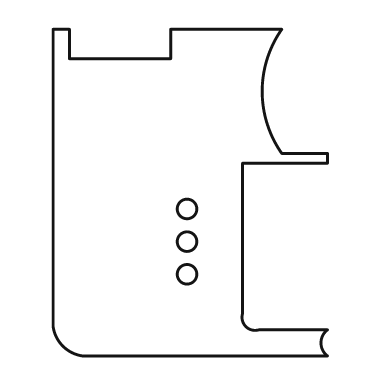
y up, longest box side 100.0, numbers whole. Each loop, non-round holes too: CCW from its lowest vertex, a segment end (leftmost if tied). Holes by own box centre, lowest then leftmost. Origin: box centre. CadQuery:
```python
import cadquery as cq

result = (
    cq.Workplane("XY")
    .moveTo(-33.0, -50.0)
    .lineTo(42.0, -50.0)
    .threePointArc((40.0, -46.0), (42.0, -42.0))
    .lineTo(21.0, -42.0)
    .threePointArc((17.0, -41.0), (16.0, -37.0))
    .lineTo(16.0, 9.0)
    .lineTo(42.0, 9.0)
    .lineTo(42.0, 12.0)
    .lineTo(28.0, 12.0)
    .threePointArc((22.0, 31.0), (28.0, 50.0))
    .lineTo(-6.0, 50.0)
    .lineTo(-6.0, 41.0)
    .lineTo(-37.0, 41.0)
    .lineTo(-37.0, 50.0)
    .lineTo(-42.0, 50.0)
    .lineTo(-42.0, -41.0)
    .threePointArc((-39.0, -47.0), (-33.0, -50.0))
    .close()
    .moveTo(-1.0, -25.0)
    .circle(3.0)
    .moveTo(-1.0, -15.0)
    .circle(3.0)
    .moveTo(-1.0, -5.0)
    .circle(3.0)
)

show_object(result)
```